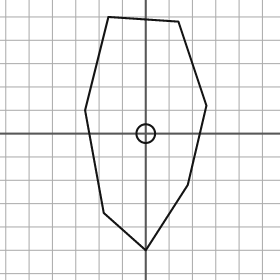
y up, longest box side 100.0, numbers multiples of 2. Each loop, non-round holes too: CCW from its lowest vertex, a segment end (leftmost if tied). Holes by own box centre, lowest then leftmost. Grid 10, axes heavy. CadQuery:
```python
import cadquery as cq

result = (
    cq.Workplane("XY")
    .moveTo(0.0, -50.0)
    .lineTo(18.0, -22.0)
    .lineTo(26.0, 12.0)
    .lineTo(14.0, 48.0)
    .lineTo(-16.0, 50.0)
    .lineTo(-26.0, 10.0)
    .lineTo(-18.0, -34.0)
    .close()
    .moveTo(0.0, 0.0)
    .circle(4.0)
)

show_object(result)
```